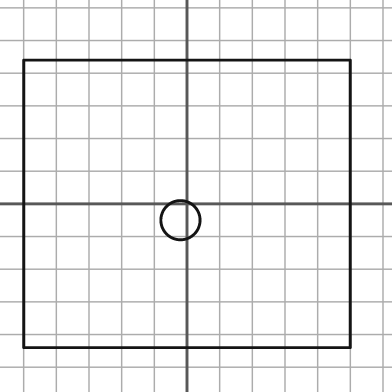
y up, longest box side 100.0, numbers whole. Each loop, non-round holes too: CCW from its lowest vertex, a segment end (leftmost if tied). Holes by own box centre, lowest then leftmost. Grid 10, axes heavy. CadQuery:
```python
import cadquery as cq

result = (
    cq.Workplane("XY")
    .moveTo(-50.0, -44.0)
    .lineTo(50.0, -44.0)
    .lineTo(50.0, 44.0)
    .lineTo(-50.0, 44.0)
    .close()
    .moveTo(-2.0, -5.0)
    .circle(6.0)
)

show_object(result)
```